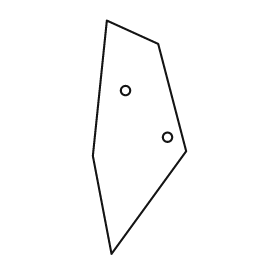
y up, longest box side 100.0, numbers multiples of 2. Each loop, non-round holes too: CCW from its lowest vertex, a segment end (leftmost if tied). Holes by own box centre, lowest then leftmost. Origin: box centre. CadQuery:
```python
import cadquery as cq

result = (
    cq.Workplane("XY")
    .moveTo(-12.0, -50.0)
    .lineTo(20.0, -6.0)
    .lineTo(8.0, 40.0)
    .lineTo(-14.0, 50.0)
    .lineTo(-20.0, -8.0)
    .close()
    .moveTo(12.0, 0.0)
    .circle(2.0)
    .moveTo(-6.0, 20.0)
    .circle(2.0)
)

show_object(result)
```